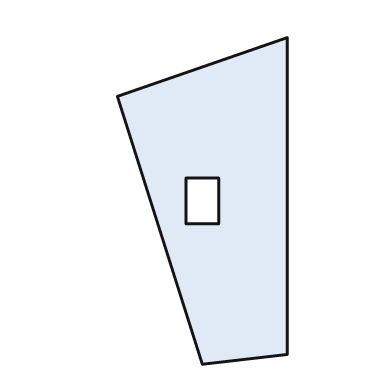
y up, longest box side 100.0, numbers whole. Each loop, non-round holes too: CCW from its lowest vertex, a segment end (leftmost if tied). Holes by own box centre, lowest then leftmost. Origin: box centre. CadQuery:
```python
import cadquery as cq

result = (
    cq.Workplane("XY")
    .moveTo(0.0, -50.0)
    .lineTo(26.0, -47.0)
    .lineTo(26.0, 50.0)
    .lineTo(-26.0, 32.0)
    .close()
    .moveTo(-5.0, -7.0)
    .lineTo(5.0, -7.0)
    .lineTo(5.0, 7.0)
    .lineTo(-5.0, 7.0)
    .close()
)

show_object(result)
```